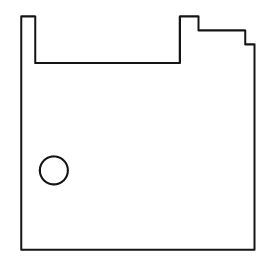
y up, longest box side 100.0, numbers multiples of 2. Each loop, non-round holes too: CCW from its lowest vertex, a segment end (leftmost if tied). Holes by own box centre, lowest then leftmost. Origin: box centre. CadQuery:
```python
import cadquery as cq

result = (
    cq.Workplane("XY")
    .moveTo(-50.0, -50.0)
    .lineTo(50.0, -50.0)
    .lineTo(50.0, 38.0)
    .lineTo(46.0, 38.0)
    .lineTo(46.0, 44.0)
    .lineTo(26.0, 44.0)
    .lineTo(26.0, 50.0)
    .lineTo(18.0, 50.0)
    .lineTo(18.0, 30.0)
    .lineTo(-44.0, 30.0)
    .lineTo(-44.0, 50.0)
    .lineTo(-50.0, 50.0)
    .close()
    .moveTo(-36.0, -16.0)
    .circle(6.0)
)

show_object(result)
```